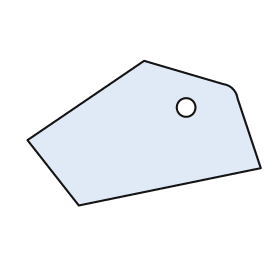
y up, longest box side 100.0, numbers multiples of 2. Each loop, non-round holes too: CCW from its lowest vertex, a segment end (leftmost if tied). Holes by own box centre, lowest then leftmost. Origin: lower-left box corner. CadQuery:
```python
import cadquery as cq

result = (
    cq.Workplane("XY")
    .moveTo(22.0, 0.0)
    .lineTo(100.0, 16.0)
    .lineTo(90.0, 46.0)
    .threePointArc((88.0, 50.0), (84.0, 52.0))
    .lineTo(50.0, 62.0)
    .lineTo(0.0, 28.0)
    .close()
    .moveTo(68.0, 42.0)
    .circle(4.0)
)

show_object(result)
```